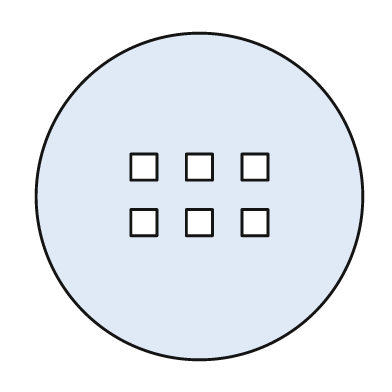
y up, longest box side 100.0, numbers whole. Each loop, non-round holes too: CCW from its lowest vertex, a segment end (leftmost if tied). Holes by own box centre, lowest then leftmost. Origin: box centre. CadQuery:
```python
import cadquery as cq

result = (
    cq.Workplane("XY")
    .moveTo(0.0, 0.0)
    .circle(50.0)
    .moveTo(-21.0, -12.0)
    .lineTo(-13.0, -12.0)
    .lineTo(-13.0, -4.0)
    .lineTo(-21.0, -4.0)
    .close()
    .moveTo(-4.0, -12.0)
    .lineTo(4.0, -12.0)
    .lineTo(4.0, -4.0)
    .lineTo(-4.0, -4.0)
    .close()
    .moveTo(13.0, -12.0)
    .lineTo(21.0, -12.0)
    .lineTo(21.0, -4.0)
    .lineTo(13.0, -4.0)
    .close()
    .moveTo(-21.0, 5.0)
    .lineTo(-13.0, 5.0)
    .lineTo(-13.0, 13.0)
    .lineTo(-21.0, 13.0)
    .close()
    .moveTo(-4.0, 5.0)
    .lineTo(4.0, 5.0)
    .lineTo(4.0, 13.0)
    .lineTo(-4.0, 13.0)
    .close()
    .moveTo(13.0, 5.0)
    .lineTo(21.0, 5.0)
    .lineTo(21.0, 13.0)
    .lineTo(13.0, 13.0)
    .close()
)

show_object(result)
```